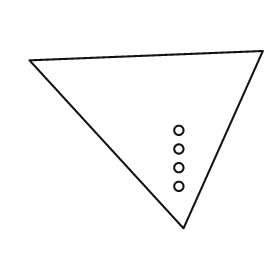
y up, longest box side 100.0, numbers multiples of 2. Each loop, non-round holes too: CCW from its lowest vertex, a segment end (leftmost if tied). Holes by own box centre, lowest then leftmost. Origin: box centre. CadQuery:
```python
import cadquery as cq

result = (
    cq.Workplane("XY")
    .moveTo(16.0, -38.0)
    .lineTo(50.0, 38.0)
    .lineTo(-50.0, 34.0)
    .close()
    .moveTo(14.0, -20.0)
    .circle(2.0)
    .moveTo(14.0, -12.0)
    .circle(2.0)
    .moveTo(14.0, -4.0)
    .circle(2.0)
    .moveTo(14.0, 4.0)
    .circle(2.0)
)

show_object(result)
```